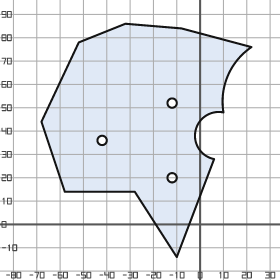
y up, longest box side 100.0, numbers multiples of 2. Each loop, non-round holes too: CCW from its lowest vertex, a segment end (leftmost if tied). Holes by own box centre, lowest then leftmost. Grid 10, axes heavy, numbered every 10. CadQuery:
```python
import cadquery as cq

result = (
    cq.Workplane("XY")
    .moveTo(-10.0, -14.0)
    .lineTo(6.0, 28.0)
    .threePointArc((-2.0, 40.0), (10.0, 48.0))
    .threePointArc((12.0, 64.0), (22.0, 76.0))
    .lineTo(-8.0, 84.0)
    .lineTo(-32.0, 86.0)
    .lineTo(-52.0, 78.0)
    .lineTo(-68.0, 44.0)
    .lineTo(-58.0, 14.0)
    .lineTo(-28.0, 14.0)
    .close()
    .moveTo(-12.0, 20.0)
    .circle(2.0)
    .moveTo(-42.0, 36.0)
    .circle(2.0)
    .moveTo(-12.0, 52.0)
    .circle(2.0)
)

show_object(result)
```